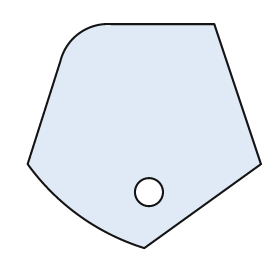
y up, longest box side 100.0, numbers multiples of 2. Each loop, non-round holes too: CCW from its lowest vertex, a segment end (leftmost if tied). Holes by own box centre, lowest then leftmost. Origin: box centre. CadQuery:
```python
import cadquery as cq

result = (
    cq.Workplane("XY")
    .moveTo(0.0, -48.0)
    .lineTo(50.0, -12.0)
    .lineTo(30.0, 48.0)
    .lineTo(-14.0, 48.0)
    .threePointArc((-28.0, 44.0), (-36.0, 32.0))
    .lineTo(-50.0, -12.0)
    .threePointArc((-28.0, -34.0), (0.0, -48.0))
    .close()
    .moveTo(2.0, -24.0)
    .circle(6.0)
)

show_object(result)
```